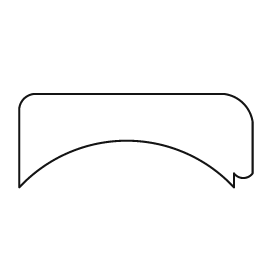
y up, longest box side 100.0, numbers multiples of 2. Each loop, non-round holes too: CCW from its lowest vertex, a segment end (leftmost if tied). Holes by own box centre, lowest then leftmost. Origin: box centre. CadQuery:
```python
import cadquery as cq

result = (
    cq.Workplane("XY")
    .moveTo(-50.0, -20.0)
    .threePointArc((-4.0, 0.0), (42.0, -20.0))
    .lineTo(42.0, -14.0)
    .threePointArc((46.0, -16.0), (50.0, -14.0))
    .lineTo(50.0, 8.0)
    .threePointArc((46.0, 16.0), (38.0, 20.0))
    .lineTo(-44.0, 20.0)
    .threePointArc((-48.0, 18.0), (-50.0, 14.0))
    .close()
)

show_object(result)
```